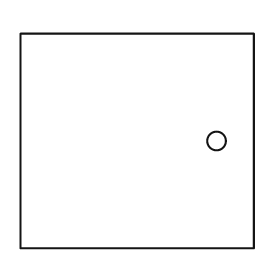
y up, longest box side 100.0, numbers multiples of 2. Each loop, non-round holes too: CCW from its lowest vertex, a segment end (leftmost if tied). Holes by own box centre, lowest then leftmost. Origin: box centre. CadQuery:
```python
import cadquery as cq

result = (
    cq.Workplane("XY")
    .moveTo(-50.0, -46.0)
    .lineTo(50.0, -46.0)
    .lineTo(50.0, 46.0)
    .lineTo(-50.0, 46.0)
    .close()
    .moveTo(34.0, 0.0)
    .circle(4.0)
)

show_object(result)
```